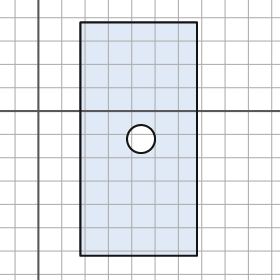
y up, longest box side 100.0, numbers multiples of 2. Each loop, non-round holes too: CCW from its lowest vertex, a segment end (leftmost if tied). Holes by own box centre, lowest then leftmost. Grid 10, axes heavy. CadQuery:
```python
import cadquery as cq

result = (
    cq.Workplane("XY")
    .moveTo(18.0, -62.0)
    .lineTo(68.0, -62.0)
    .lineTo(68.0, 38.0)
    .lineTo(18.0, 38.0)
    .close()
    .moveTo(44.0, -12.0)
    .circle(6.0)
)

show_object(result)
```